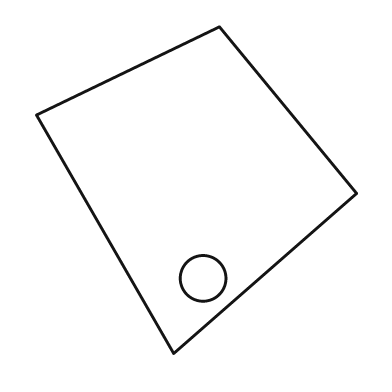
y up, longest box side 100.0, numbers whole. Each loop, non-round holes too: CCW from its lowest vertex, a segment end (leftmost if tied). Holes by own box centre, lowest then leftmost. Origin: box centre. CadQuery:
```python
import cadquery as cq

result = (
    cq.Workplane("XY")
    .moveTo(-7.0, -50.0)
    .lineTo(49.0, -1.0)
    .lineTo(7.0, 50.0)
    .lineTo(-49.0, 23.0)
    .close()
    .moveTo(2.0, -27.0)
    .circle(7.0)
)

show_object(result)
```